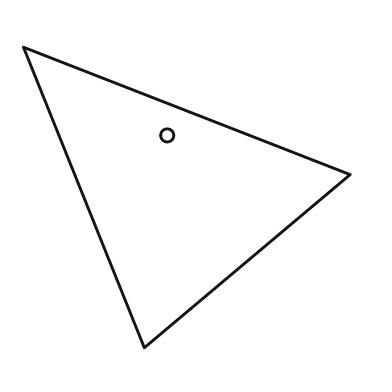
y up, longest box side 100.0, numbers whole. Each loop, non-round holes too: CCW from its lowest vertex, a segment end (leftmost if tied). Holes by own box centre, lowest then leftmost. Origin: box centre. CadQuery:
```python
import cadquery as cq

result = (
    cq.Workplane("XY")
    .moveTo(-13.0, -46.0)
    .lineTo(50.0, 7.0)
    .lineTo(-50.0, 46.0)
    .close()
    .moveTo(-6.0, 19.0)
    .circle(2.0)
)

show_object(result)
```